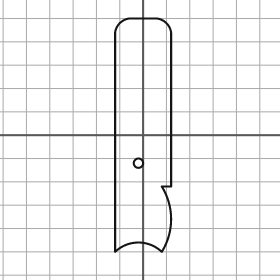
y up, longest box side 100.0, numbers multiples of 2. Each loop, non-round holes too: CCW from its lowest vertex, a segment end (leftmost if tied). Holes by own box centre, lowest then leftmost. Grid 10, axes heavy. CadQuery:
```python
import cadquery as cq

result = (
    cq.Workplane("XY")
    .moveTo(-12.0, -50.0)
    .threePointArc((-2.0, -46.0), (8.0, -50.0))
    .threePointArc((12.0, -36.0), (8.0, -22.0))
    .lineTo(12.0, -22.0)
    .lineTo(12.0, 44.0)
    .threePointArc((10.0, 48.0), (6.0, 50.0))
    .lineTo(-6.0, 50.0)
    .threePointArc((-10.0, 48.0), (-12.0, 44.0))
    .close()
    .moveTo(-2.0, -12.0)
    .circle(2.0)
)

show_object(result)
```